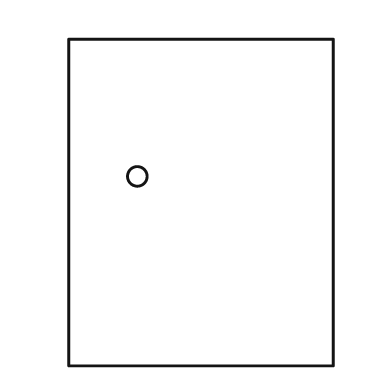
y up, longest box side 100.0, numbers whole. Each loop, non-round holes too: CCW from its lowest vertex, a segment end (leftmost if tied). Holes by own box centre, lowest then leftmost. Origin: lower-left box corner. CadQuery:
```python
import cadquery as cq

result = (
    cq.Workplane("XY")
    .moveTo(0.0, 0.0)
    .lineTo(81.0, 0.0)
    .lineTo(81.0, 100.0)
    .lineTo(0.0, 100.0)
    .close()
    .moveTo(21.0, 58.0)
    .circle(3.0)
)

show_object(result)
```